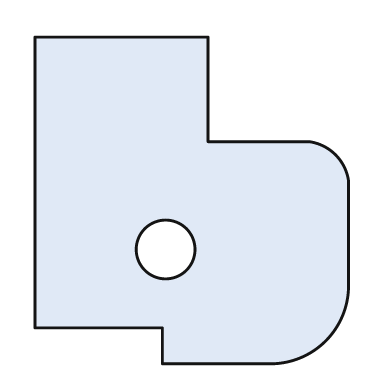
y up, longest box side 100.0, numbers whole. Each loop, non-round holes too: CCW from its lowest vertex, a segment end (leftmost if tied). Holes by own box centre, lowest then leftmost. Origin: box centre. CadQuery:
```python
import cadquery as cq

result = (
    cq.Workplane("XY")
    .moveTo(-9.0, -50.0)
    .lineTo(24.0, -50.0)
    .threePointArc((41.0, -43.0), (48.0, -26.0))
    .lineTo(48.0, 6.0)
    .threePointArc((44.0, 14.0), (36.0, 18.0))
    .lineTo(5.0, 18.0)
    .lineTo(5.0, 50.0)
    .lineTo(-48.0, 50.0)
    .lineTo(-48.0, -39.0)
    .lineTo(-9.0, -39.0)
    .close()
    .moveTo(-8.0, -15.0)
    .circle(9.0)
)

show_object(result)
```